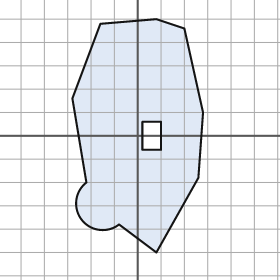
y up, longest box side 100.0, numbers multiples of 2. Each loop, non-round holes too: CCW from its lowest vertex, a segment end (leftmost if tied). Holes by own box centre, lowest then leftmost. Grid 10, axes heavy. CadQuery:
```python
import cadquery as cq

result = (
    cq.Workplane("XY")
    .moveTo(8.0, -50.0)
    .lineTo(26.0, -18.0)
    .lineTo(28.0, 10.0)
    .lineTo(20.0, 46.0)
    .lineTo(8.0, 50.0)
    .lineTo(-16.0, 48.0)
    .lineTo(-28.0, 16.0)
    .lineTo(-22.0, -20.0)
    .threePointArc((-24.0, -36.0), (-8.0, -38.0))
    .close()
    .moveTo(2.0, -6.0)
    .lineTo(10.0, -6.0)
    .lineTo(10.0, 6.0)
    .lineTo(2.0, 6.0)
    .close()
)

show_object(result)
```